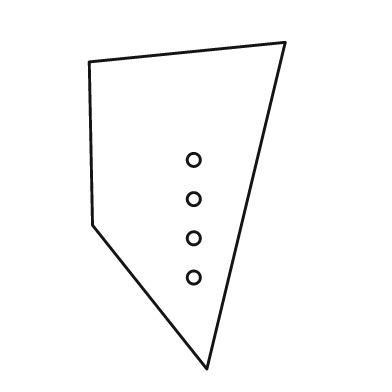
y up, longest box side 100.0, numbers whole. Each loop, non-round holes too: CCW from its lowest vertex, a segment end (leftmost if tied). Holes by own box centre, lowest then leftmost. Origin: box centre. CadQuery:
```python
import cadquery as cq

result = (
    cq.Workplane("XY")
    .moveTo(6.0, -50.0)
    .lineTo(30.0, 50.0)
    .lineTo(-30.0, 44.0)
    .lineTo(-29.0, -6.0)
    .close()
    .moveTo(2.0, -22.0)
    .circle(2.0)
    .moveTo(2.0, -10.0)
    .circle(2.0)
    .moveTo(2.0, 2.0)
    .circle(2.0)
    .moveTo(2.0, 14.0)
    .circle(2.0)
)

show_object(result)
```